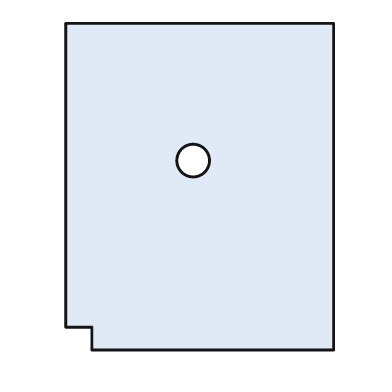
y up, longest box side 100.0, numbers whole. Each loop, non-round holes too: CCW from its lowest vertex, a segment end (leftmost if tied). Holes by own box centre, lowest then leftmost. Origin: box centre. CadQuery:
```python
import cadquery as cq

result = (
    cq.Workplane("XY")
    .moveTo(-33.0, -50.0)
    .lineTo(41.0, -50.0)
    .lineTo(41.0, 50.0)
    .lineTo(-41.0, 50.0)
    .lineTo(-41.0, -43.0)
    .lineTo(-33.0, -43.0)
    .close()
    .moveTo(-2.0, 8.0)
    .circle(5.0)
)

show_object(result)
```